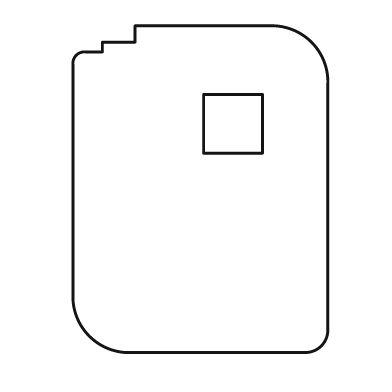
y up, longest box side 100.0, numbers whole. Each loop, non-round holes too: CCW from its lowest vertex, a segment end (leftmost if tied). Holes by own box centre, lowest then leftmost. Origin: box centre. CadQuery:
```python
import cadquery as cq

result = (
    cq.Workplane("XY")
    .moveTo(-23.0, -50.0)
    .lineTo(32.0, -50.0)
    .threePointArc((37.0, -48.0), (39.0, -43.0))
    .lineTo(39.0, 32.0)
    .threePointArc((34.0, 45.0), (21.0, 50.0))
    .lineTo(-20.0, 50.0)
    .lineTo(-20.0, 45.0)
    .lineTo(-30.0, 45.0)
    .lineTo(-30.0, 42.0)
    .lineTo(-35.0, 42.0)
    .threePointArc((-38.0, 41.0), (-39.0, 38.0))
    .lineTo(-39.0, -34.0)
    .threePointArc((-34.0, -45.0), (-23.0, -50.0))
    .close()
    .moveTo(1.0, 11.0)
    .lineTo(19.0, 11.0)
    .lineTo(19.0, 29.0)
    .lineTo(1.0, 29.0)
    .close()
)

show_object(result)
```